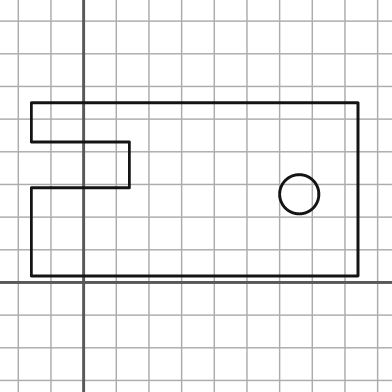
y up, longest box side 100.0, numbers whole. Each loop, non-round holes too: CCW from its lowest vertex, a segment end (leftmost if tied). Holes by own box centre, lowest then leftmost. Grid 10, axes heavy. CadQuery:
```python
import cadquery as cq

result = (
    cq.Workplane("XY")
    .moveTo(-16.0, 2.0)
    .lineTo(84.0, 2.0)
    .lineTo(84.0, 55.0)
    .lineTo(-16.0, 55.0)
    .lineTo(-16.0, 43.0)
    .lineTo(14.0, 43.0)
    .lineTo(14.0, 29.0)
    .lineTo(-16.0, 29.0)
    .close()
    .moveTo(66.0, 27.0)
    .circle(6.0)
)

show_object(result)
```